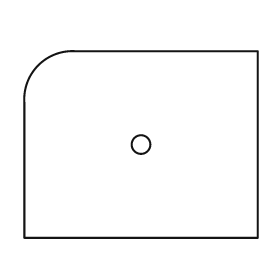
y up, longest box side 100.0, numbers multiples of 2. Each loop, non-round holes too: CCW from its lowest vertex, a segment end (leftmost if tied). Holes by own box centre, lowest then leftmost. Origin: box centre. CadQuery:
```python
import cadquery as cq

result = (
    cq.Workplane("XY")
    .moveTo(-50.0, -40.0)
    .lineTo(50.0, -40.0)
    .lineTo(50.0, 40.0)
    .lineTo(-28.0, 40.0)
    .threePointArc((-44.0, 34.0), (-50.0, 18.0))
    .close()
    .moveTo(0.0, 0.0)
    .circle(4.0)
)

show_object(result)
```